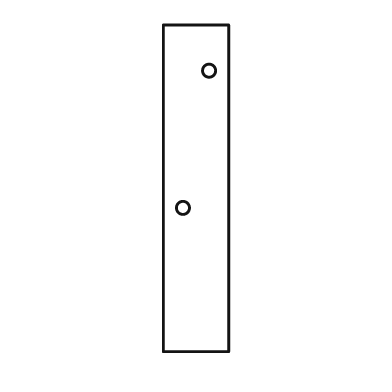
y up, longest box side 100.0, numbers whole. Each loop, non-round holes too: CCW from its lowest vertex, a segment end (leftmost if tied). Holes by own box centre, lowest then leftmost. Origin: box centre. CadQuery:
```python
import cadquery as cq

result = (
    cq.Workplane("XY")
    .moveTo(-10.0, -50.0)
    .lineTo(10.0, -50.0)
    .lineTo(10.0, 50.0)
    .lineTo(-10.0, 50.0)
    .close()
    .moveTo(-4.0, -6.0)
    .circle(2.0)
    .moveTo(4.0, 36.0)
    .circle(2.0)
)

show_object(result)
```